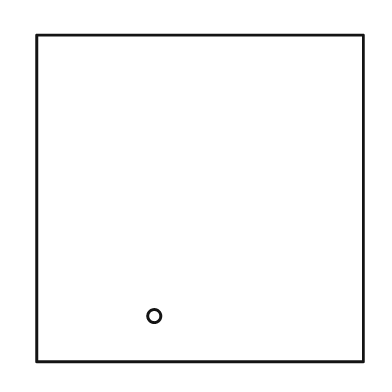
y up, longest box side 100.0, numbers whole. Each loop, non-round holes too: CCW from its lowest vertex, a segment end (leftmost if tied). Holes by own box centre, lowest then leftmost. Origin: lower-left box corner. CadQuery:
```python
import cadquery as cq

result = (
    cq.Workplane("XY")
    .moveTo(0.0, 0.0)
    .lineTo(100.0, 0.0)
    .lineTo(100.0, 100.0)
    .lineTo(0.0, 100.0)
    .close()
    .moveTo(36.0, 14.0)
    .circle(2.0)
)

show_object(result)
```